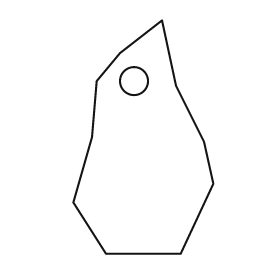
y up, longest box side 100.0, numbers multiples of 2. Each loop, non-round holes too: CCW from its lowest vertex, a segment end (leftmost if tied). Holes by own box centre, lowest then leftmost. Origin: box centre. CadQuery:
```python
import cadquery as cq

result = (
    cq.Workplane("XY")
    .moveTo(-16.0, -50.0)
    .lineTo(16.0, -50.0)
    .lineTo(30.0, -20.0)
    .lineTo(26.0, -2.0)
    .lineTo(14.0, 22.0)
    .lineTo(8.0, 50.0)
    .lineTo(-10.0, 36.0)
    .lineTo(-20.0, 24.0)
    .lineTo(-22.0, 0.0)
    .lineTo(-30.0, -28.0)
    .close()
    .moveTo(-4.0, 24.0)
    .circle(6.0)
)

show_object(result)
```